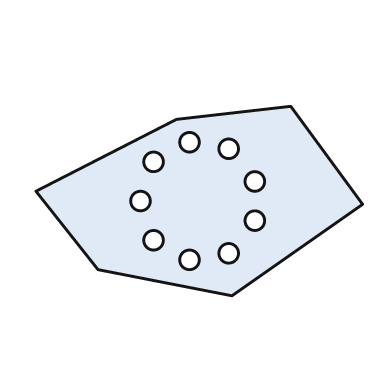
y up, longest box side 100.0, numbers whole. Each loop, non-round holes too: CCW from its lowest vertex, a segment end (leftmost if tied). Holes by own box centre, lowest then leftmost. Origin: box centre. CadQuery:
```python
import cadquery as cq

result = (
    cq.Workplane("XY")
    .moveTo(10.0, -29.0)
    .lineTo(50.0, -1.0)
    .lineTo(28.0, 29.0)
    .lineTo(-7.0, 25.0)
    .lineTo(-50.0, 3.0)
    .lineTo(-31.0, -21.0)
    .close()
    .moveTo(-3.0, -18.0)
    .circle(3.0)
    .moveTo(9.0, -16.0)
    .circle(3.0)
    .moveTo(-14.0, -12.0)
    .circle(3.0)
    .moveTo(17.0, -6.0)
    .circle(3.0)
    .moveTo(-18.0, 0.0)
    .circle(3.0)
    .moveTo(17.0, 6.0)
    .circle(3.0)
    .moveTo(-14.0, 12.0)
    .circle(3.0)
    .moveTo(9.0, 16.0)
    .circle(3.0)
    .moveTo(-3.0, 18.0)
    .circle(3.0)
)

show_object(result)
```